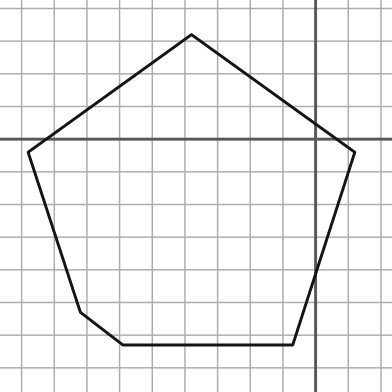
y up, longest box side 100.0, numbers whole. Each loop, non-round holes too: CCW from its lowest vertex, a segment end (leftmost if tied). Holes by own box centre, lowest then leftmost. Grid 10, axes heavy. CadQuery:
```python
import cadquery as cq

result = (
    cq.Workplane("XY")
    .moveTo(-59.0, -63.0)
    .lineTo(-7.0, -63.0)
    .lineTo(12.0, -4.0)
    .lineTo(-38.0, 32.0)
    .lineTo(-88.0, -4.0)
    .lineTo(-72.0, -53.0)
    .close()
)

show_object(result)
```